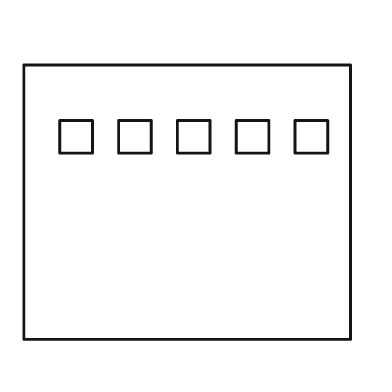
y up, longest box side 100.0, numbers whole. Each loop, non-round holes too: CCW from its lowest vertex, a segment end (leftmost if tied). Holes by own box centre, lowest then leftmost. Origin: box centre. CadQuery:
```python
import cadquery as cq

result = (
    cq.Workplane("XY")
    .moveTo(-50.0, -42.0)
    .lineTo(50.0, -42.0)
    .lineTo(50.0, 42.0)
    .lineTo(-50.0, 42.0)
    .close()
    .moveTo(-39.0, 15.0)
    .lineTo(-29.0, 15.0)
    .lineTo(-29.0, 25.0)
    .lineTo(-39.0, 25.0)
    .close()
    .moveTo(-21.0, 15.0)
    .lineTo(-11.0, 15.0)
    .lineTo(-11.0, 25.0)
    .lineTo(-21.0, 25.0)
    .close()
    .moveTo(-3.0, 15.0)
    .lineTo(7.0, 15.0)
    .lineTo(7.0, 25.0)
    .lineTo(-3.0, 25.0)
    .close()
    .moveTo(15.0, 15.0)
    .lineTo(25.0, 15.0)
    .lineTo(25.0, 25.0)
    .lineTo(15.0, 25.0)
    .close()
    .moveTo(33.0, 15.0)
    .lineTo(43.0, 15.0)
    .lineTo(43.0, 25.0)
    .lineTo(33.0, 25.0)
    .close()
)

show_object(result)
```